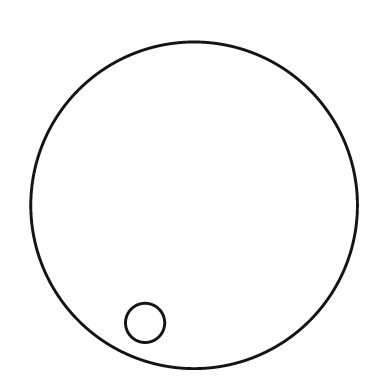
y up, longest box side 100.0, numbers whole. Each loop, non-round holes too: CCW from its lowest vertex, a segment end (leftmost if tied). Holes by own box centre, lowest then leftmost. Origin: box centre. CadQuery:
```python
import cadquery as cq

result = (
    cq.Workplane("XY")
    .moveTo(0.0, 0.0)
    .circle(50.0)
    .moveTo(-15.0, -36.0)
    .circle(6.0)
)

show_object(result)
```